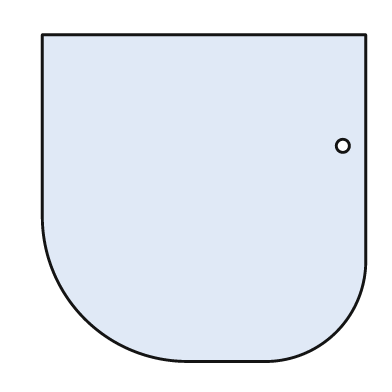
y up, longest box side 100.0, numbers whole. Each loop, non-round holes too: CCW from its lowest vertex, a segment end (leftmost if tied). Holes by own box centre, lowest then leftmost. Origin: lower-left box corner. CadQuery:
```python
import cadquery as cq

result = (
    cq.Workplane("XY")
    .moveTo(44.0, 0.0)
    .lineTo(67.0, 0.0)
    .threePointArc((90.0, 9.0), (99.0, 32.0))
    .lineTo(99.0, 100.0)
    .lineTo(0.0, 100.0)
    .lineTo(0.0, 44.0)
    .threePointArc((13.0, 13.0), (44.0, 0.0))
    .close()
    .moveTo(92.0, 66.0)
    .circle(2.0)
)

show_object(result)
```